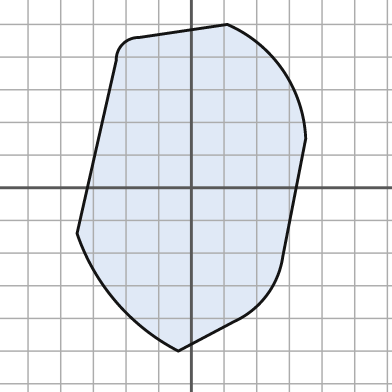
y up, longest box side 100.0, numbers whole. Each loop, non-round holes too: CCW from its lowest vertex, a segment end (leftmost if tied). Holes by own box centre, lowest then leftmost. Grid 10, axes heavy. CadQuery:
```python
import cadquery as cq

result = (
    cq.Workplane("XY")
    .moveTo(-4.0, -50.0)
    .lineTo(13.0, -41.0)
    .threePointArc((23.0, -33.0), (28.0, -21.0))
    .lineTo(35.0, 15.0)
    .threePointArc((28.0, 36.0), (11.0, 50.0))
    .lineTo(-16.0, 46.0)
    .threePointArc((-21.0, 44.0), (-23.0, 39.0))
    .lineTo(-35.0, -14.0)
    .threePointArc((-23.0, -35.0), (-4.0, -50.0))
    .close()
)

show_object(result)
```